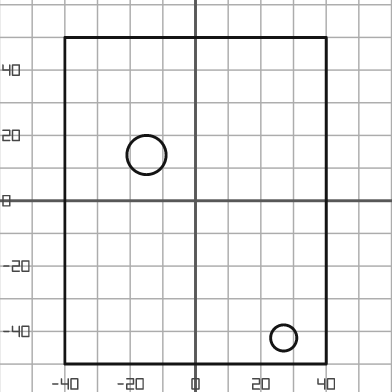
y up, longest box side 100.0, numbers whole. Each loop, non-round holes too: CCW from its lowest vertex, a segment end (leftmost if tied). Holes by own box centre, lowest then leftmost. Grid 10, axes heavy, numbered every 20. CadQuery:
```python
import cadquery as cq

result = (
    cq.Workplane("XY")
    .moveTo(-40.0, -50.0)
    .lineTo(40.0, -50.0)
    .lineTo(40.0, 50.0)
    .lineTo(-40.0, 50.0)
    .close()
    .moveTo(27.0, -42.0)
    .circle(4.0)
    .moveTo(-15.0, 14.0)
    .circle(6.0)
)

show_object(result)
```